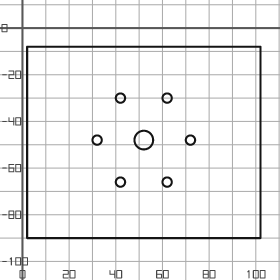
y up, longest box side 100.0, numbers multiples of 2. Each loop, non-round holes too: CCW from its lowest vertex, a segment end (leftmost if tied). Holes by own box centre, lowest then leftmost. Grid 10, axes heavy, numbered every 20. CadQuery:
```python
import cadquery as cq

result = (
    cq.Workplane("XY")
    .moveTo(2.0, -90.0)
    .lineTo(102.0, -90.0)
    .lineTo(102.0, -8.0)
    .lineTo(2.0, -8.0)
    .close()
    .moveTo(42.0, -66.0)
    .circle(2.0)
    .moveTo(62.0, -66.0)
    .circle(2.0)
    .moveTo(32.0, -48.0)
    .circle(2.0)
    .moveTo(52.0, -48.0)
    .circle(4.0)
    .moveTo(72.0, -48.0)
    .circle(2.0)
    .moveTo(42.0, -30.0)
    .circle(2.0)
    .moveTo(62.0, -30.0)
    .circle(2.0)
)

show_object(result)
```